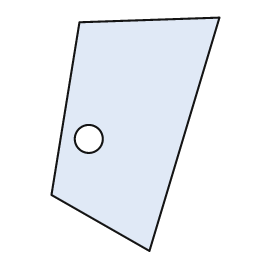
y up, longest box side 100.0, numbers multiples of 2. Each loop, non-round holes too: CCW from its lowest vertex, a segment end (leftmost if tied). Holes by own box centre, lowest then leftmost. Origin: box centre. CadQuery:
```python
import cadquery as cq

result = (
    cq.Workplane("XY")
    .moveTo(6.0, -50.0)
    .lineTo(36.0, 50.0)
    .lineTo(-24.0, 48.0)
    .lineTo(-36.0, -26.0)
    .close()
    .moveTo(-20.0, -2.0)
    .circle(6.0)
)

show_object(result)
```